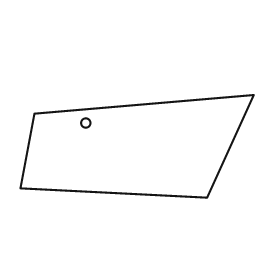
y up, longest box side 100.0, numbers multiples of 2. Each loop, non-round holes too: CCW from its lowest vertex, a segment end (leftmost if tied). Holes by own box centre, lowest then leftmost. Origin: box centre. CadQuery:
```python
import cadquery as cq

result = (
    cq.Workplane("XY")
    .moveTo(30.0, -22.0)
    .lineTo(50.0, 22.0)
    .lineTo(-44.0, 14.0)
    .lineTo(-50.0, -18.0)
    .close()
    .moveTo(-22.0, 10.0)
    .circle(2.0)
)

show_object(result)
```